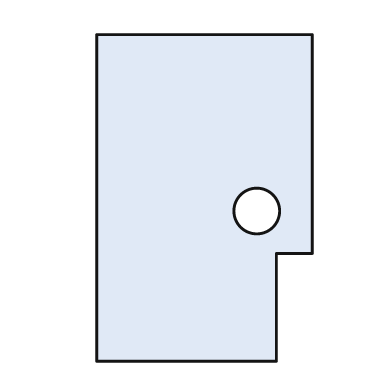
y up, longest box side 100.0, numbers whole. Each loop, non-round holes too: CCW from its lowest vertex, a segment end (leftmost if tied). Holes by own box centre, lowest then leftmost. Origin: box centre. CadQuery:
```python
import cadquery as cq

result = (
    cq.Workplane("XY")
    .moveTo(-33.0, -50.0)
    .lineTo(22.0, -50.0)
    .lineTo(22.0, -17.0)
    .lineTo(33.0, -17.0)
    .lineTo(33.0, 50.0)
    .lineTo(-33.0, 50.0)
    .close()
    .moveTo(16.0, -4.0)
    .circle(7.0)
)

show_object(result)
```